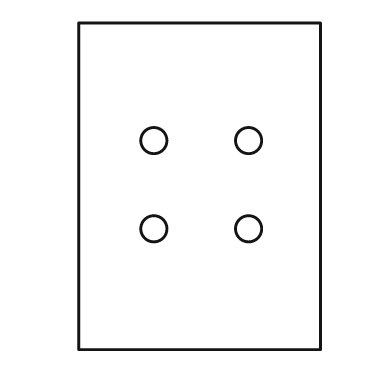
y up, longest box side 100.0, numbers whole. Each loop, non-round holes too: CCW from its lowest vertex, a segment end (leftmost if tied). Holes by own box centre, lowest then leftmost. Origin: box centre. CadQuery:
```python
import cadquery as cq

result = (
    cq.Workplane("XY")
    .moveTo(-37.0, -50.0)
    .lineTo(37.0, -50.0)
    .lineTo(37.0, 50.0)
    .lineTo(-37.0, 50.0)
    .close()
    .moveTo(-14.0, -13.0)
    .circle(4.0)
    .moveTo(15.0, -13.0)
    .circle(4.0)
    .moveTo(-14.0, 14.0)
    .circle(4.0)
    .moveTo(15.0, 14.0)
    .circle(4.0)
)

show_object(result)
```